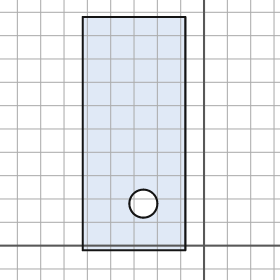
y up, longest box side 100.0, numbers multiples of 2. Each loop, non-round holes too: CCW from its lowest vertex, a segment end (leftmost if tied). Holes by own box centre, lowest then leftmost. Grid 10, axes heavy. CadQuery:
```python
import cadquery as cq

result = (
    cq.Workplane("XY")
    .moveTo(-52.0, -2.0)
    .lineTo(-8.0, -2.0)
    .lineTo(-8.0, 98.0)
    .lineTo(-52.0, 98.0)
    .close()
    .moveTo(-26.0, 18.0)
    .circle(6.0)
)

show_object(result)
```